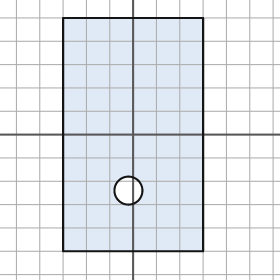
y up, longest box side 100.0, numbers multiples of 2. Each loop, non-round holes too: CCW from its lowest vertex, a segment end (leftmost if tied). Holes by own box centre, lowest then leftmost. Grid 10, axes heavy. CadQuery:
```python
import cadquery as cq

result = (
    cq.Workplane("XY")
    .moveTo(-30.0, -50.0)
    .lineTo(30.0, -50.0)
    .lineTo(30.0, 50.0)
    .lineTo(-30.0, 50.0)
    .close()
    .moveTo(-2.0, -24.0)
    .circle(6.0)
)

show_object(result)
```